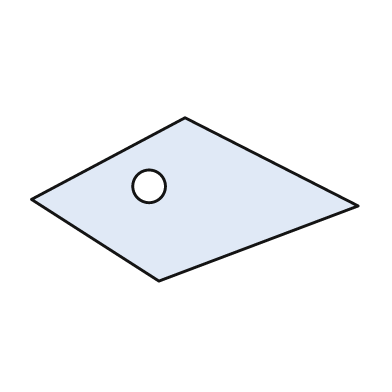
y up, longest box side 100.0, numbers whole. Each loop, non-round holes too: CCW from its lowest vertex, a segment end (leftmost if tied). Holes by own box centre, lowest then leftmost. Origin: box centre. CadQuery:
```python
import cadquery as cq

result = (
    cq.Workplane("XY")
    .moveTo(-11.0, -25.0)
    .lineTo(50.0, -2.0)
    .lineTo(-3.0, 25.0)
    .lineTo(-50.0, 0.0)
    .close()
    .moveTo(-14.0, 4.0)
    .circle(5.0)
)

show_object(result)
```